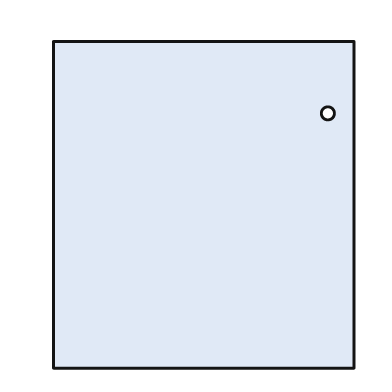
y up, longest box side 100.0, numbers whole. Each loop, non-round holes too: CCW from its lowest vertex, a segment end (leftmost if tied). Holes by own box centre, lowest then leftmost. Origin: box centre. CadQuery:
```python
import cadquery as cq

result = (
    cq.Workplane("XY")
    .moveTo(-46.0, -50.0)
    .lineTo(46.0, -50.0)
    .lineTo(46.0, 50.0)
    .lineTo(-46.0, 50.0)
    .close()
    .moveTo(38.0, 28.0)
    .circle(2.0)
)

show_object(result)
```